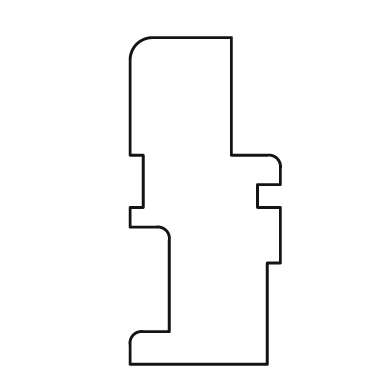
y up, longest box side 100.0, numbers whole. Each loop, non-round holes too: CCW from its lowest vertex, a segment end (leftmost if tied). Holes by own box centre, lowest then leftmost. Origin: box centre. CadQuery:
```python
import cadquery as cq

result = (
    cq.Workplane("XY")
    .moveTo(-23.0, -50.0)
    .lineTo(19.0, -50.0)
    .lineTo(19.0, -19.0)
    .lineTo(23.0, -19.0)
    .lineTo(23.0, -2.0)
    .lineTo(16.0, -2.0)
    .lineTo(16.0, 5.0)
    .lineTo(23.0, 5.0)
    .lineTo(23.0, 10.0)
    .threePointArc((22.0, 13.0), (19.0, 14.0))
    .lineTo(8.0, 14.0)
    .lineTo(8.0, 50.0)
    .lineTo(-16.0, 50.0)
    .threePointArc((-21.0, 48.0), (-23.0, 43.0))
    .lineTo(-23.0, 14.0)
    .lineTo(-19.0, 14.0)
    .lineTo(-19.0, -2.0)
    .lineTo(-23.0, -2.0)
    .lineTo(-23.0, -8.0)
    .lineTo(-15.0, -8.0)
    .threePointArc((-12.0, -9.0), (-11.0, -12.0))
    .lineTo(-11.0, -40.0)
    .lineTo(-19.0, -40.0)
    .threePointArc((-22.0, -41.0), (-23.0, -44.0))
    .close()
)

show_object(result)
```